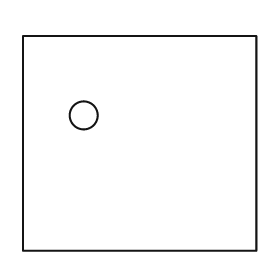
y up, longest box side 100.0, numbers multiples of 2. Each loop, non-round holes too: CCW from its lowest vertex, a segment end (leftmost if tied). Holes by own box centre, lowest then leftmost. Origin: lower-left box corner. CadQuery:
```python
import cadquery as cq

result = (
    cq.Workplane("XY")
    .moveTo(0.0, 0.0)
    .lineTo(100.0, 0.0)
    .lineTo(100.0, 92.0)
    .lineTo(0.0, 92.0)
    .close()
    .moveTo(26.0, 58.0)
    .circle(6.0)
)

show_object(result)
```